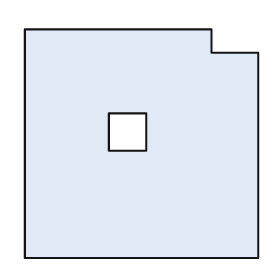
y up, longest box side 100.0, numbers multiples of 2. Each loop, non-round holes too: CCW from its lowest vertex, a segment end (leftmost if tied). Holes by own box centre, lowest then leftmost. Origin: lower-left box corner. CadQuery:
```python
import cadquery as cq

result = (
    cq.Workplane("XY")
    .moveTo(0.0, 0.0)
    .lineTo(100.0, 0.0)
    .lineTo(100.0, 88.0)
    .lineTo(80.0, 88.0)
    .lineTo(80.0, 98.0)
    .lineTo(0.0, 98.0)
    .close()
    .moveTo(36.0, 46.0)
    .lineTo(52.0, 46.0)
    .lineTo(52.0, 62.0)
    .lineTo(36.0, 62.0)
    .close()
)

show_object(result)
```